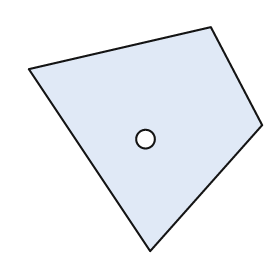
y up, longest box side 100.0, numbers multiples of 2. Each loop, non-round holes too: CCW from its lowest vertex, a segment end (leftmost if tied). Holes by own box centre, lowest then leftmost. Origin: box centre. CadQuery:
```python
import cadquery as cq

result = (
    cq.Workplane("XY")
    .moveTo(2.0, -48.0)
    .lineTo(50.0, 6.0)
    .lineTo(28.0, 48.0)
    .lineTo(-50.0, 30.0)
    .close()
    .moveTo(0.0, 0.0)
    .circle(4.0)
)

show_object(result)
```